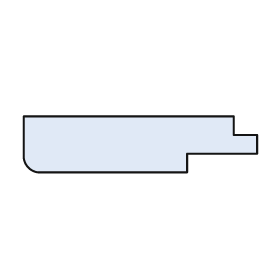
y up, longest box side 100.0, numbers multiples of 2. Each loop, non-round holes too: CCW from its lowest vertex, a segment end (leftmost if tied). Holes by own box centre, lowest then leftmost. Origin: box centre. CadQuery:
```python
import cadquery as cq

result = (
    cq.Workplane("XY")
    .moveTo(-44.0, -12.0)
    .lineTo(20.0, -12.0)
    .lineTo(20.0, -4.0)
    .lineTo(50.0, -4.0)
    .lineTo(50.0, 4.0)
    .lineTo(40.0, 4.0)
    .lineTo(40.0, 12.0)
    .lineTo(-50.0, 12.0)
    .lineTo(-50.0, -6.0)
    .threePointArc((-48.0, -10.0), (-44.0, -12.0))
    .close()
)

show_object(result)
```